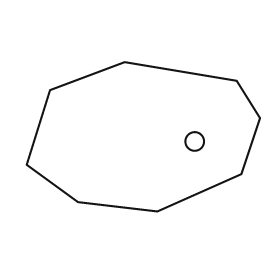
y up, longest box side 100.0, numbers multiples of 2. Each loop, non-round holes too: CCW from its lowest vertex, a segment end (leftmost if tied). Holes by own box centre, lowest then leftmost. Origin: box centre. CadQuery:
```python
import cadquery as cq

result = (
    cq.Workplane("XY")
    .moveTo(6.0, -32.0)
    .lineTo(42.0, -16.0)
    .lineTo(50.0, 8.0)
    .lineTo(40.0, 24.0)
    .lineTo(-8.0, 32.0)
    .lineTo(-40.0, 20.0)
    .lineTo(-50.0, -12.0)
    .lineTo(-28.0, -28.0)
    .close()
    .moveTo(22.0, -2.0)
    .circle(4.0)
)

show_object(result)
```